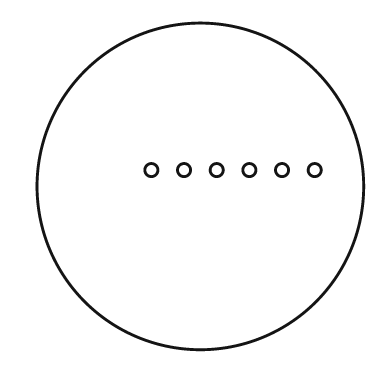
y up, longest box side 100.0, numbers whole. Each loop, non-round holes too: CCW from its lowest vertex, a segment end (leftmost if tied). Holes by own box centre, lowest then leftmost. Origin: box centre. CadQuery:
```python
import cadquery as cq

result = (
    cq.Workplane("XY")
    .moveTo(0.0, 0.0)
    .circle(50.0)
    .moveTo(-15.0, 5.0)
    .circle(2.0)
    .moveTo(-5.0, 5.0)
    .circle(2.0)
    .moveTo(5.0, 5.0)
    .circle(2.0)
    .moveTo(15.0, 5.0)
    .circle(2.0)
    .moveTo(25.0, 5.0)
    .circle(2.0)
    .moveTo(35.0, 5.0)
    .circle(2.0)
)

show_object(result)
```